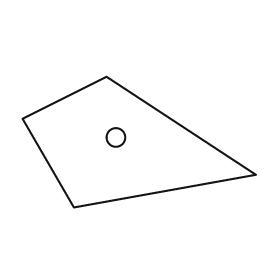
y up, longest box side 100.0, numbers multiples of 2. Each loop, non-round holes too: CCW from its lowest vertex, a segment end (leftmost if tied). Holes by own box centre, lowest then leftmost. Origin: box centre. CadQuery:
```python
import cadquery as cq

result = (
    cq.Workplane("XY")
    .moveTo(-28.0, -28.0)
    .lineTo(50.0, -14.0)
    .lineTo(-14.0, 28.0)
    .lineTo(-50.0, 10.0)
    .close()
    .moveTo(-10.0, 2.0)
    .circle(4.0)
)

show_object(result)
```